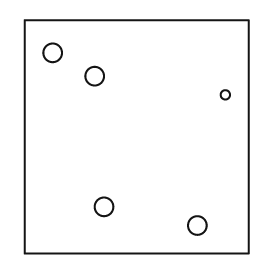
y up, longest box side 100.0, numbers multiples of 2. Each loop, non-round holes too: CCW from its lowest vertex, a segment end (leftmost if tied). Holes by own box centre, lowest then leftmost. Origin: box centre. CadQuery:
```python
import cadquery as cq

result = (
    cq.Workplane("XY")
    .moveTo(-48.0, -50.0)
    .lineTo(48.0, -50.0)
    .lineTo(48.0, 50.0)
    .lineTo(-48.0, 50.0)
    .close()
    .moveTo(26.0, -38.0)
    .circle(4.0)
    .moveTo(-14.0, -30.0)
    .circle(4.0)
    .moveTo(38.0, 18.0)
    .circle(2.0)
    .moveTo(-18.0, 26.0)
    .circle(4.0)
    .moveTo(-36.0, 36.0)
    .circle(4.0)
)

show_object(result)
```